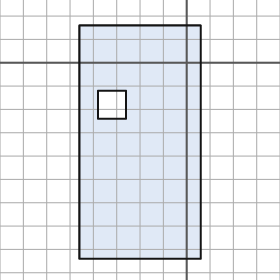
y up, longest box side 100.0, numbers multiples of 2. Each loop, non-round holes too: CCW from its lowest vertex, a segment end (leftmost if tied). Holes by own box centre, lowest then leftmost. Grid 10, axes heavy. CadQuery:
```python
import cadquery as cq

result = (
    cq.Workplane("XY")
    .moveTo(-46.0, -84.0)
    .lineTo(6.0, -84.0)
    .lineTo(6.0, 16.0)
    .lineTo(-46.0, 16.0)
    .close()
    .moveTo(-38.0, -24.0)
    .lineTo(-26.0, -24.0)
    .lineTo(-26.0, -12.0)
    .lineTo(-38.0, -12.0)
    .close()
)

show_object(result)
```